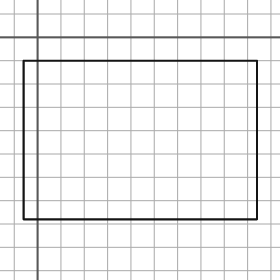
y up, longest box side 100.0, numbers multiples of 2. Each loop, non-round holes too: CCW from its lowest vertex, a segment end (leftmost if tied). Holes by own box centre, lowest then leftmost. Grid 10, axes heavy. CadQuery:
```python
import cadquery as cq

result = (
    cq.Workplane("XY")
    .moveTo(-6.0, -78.0)
    .lineTo(94.0, -78.0)
    .lineTo(94.0, -10.0)
    .lineTo(-6.0, -10.0)
    .close()
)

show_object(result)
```